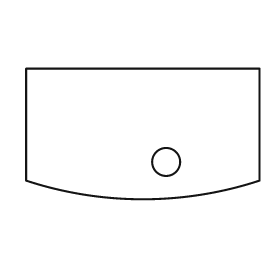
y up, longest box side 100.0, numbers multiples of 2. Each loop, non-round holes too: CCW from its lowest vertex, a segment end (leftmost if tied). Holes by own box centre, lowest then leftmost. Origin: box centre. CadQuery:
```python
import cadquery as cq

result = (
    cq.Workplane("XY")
    .moveTo(-50.0, -20.0)
    .threePointArc((0.0, -28.0), (50.0, -20.0))
    .lineTo(50.0, 28.0)
    .lineTo(-50.0, 28.0)
    .close()
    .moveTo(10.0, -12.0)
    .circle(6.0)
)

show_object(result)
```